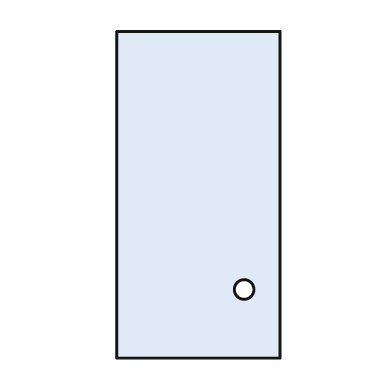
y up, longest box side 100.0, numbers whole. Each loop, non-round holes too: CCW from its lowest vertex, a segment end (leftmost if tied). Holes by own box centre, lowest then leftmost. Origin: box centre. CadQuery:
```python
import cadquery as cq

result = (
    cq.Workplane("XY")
    .moveTo(-25.0, -50.0)
    .lineTo(25.0, -50.0)
    .lineTo(25.0, 50.0)
    .lineTo(-25.0, 50.0)
    .close()
    .moveTo(14.0, -29.0)
    .circle(3.0)
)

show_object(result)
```